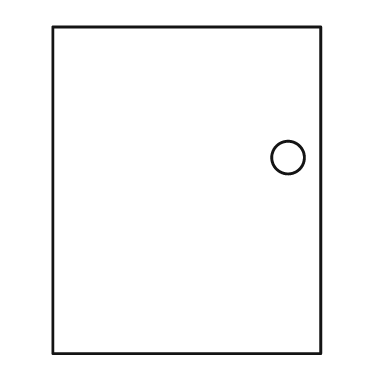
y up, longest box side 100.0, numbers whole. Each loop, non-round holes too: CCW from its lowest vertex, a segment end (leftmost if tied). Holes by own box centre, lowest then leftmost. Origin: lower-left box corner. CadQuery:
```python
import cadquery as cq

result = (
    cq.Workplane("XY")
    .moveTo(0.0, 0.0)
    .lineTo(82.0, 0.0)
    .lineTo(82.0, 100.0)
    .lineTo(0.0, 100.0)
    .close()
    .moveTo(72.0, 60.0)
    .circle(5.0)
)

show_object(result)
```